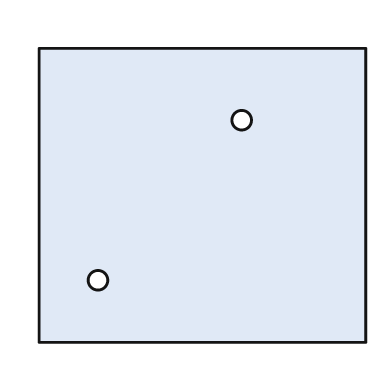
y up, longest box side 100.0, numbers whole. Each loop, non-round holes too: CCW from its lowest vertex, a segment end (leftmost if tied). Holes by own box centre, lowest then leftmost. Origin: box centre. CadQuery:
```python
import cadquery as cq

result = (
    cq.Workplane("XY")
    .moveTo(-50.0, -45.0)
    .lineTo(50.0, -45.0)
    .lineTo(50.0, 45.0)
    .lineTo(-50.0, 45.0)
    .close()
    .moveTo(-32.0, -26.0)
    .circle(3.0)
    .moveTo(12.0, 23.0)
    .circle(3.0)
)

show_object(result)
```